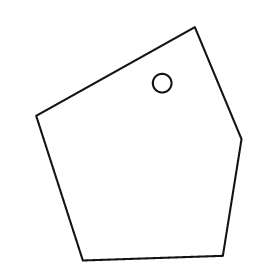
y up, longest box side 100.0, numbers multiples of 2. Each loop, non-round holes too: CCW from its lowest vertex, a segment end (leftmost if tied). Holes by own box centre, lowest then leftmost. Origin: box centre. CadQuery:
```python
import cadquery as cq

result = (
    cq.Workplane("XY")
    .moveTo(-24.0, -50.0)
    .lineTo(36.0, -48.0)
    .lineTo(44.0, 2.0)
    .lineTo(24.0, 50.0)
    .lineTo(-44.0, 12.0)
    .close()
    .moveTo(10.0, 26.0)
    .circle(4.0)
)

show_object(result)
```